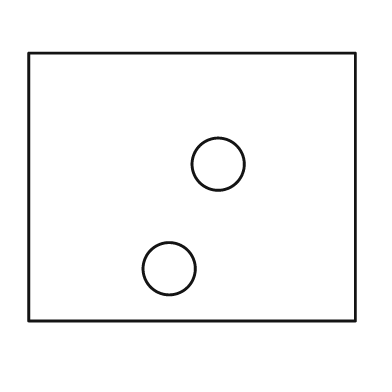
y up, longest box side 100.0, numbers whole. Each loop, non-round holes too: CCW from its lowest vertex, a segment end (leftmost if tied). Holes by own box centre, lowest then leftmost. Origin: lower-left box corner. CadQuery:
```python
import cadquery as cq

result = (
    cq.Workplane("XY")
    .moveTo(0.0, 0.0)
    .lineTo(100.0, 0.0)
    .lineTo(100.0, 82.0)
    .lineTo(0.0, 82.0)
    .close()
    .moveTo(43.0, 16.0)
    .circle(8.0)
    .moveTo(58.0, 48.0)
    .circle(8.0)
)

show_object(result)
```